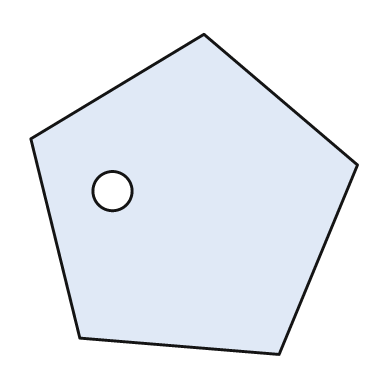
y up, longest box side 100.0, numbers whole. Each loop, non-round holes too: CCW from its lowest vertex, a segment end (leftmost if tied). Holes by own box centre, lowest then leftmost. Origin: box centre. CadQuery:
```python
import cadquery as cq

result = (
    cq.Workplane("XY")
    .moveTo(26.0, -49.0)
    .lineTo(50.0, 9.0)
    .lineTo(3.0, 49.0)
    .lineTo(-50.0, 17.0)
    .lineTo(-35.0, -44.0)
    .close()
    .moveTo(-25.0, 1.0)
    .circle(6.0)
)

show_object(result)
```